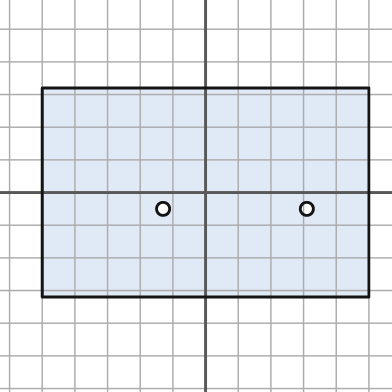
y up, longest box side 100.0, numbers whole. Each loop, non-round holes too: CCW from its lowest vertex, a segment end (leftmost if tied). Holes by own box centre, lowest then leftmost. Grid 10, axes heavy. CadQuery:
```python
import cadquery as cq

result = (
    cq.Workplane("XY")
    .moveTo(-50.0, -32.0)
    .lineTo(50.0, -32.0)
    .lineTo(50.0, 32.0)
    .lineTo(-50.0, 32.0)
    .close()
    .moveTo(-13.0, -5.0)
    .circle(2.0)
    .moveTo(31.0, -5.0)
    .circle(2.0)
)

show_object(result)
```